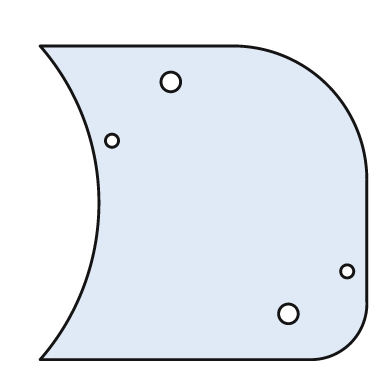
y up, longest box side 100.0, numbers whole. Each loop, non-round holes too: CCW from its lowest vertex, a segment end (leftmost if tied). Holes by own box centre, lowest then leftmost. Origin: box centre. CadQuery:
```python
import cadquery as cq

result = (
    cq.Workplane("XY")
    .moveTo(-50.0, -48.0)
    .lineTo(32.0, -48.0)
    .threePointArc((45.0, -43.0), (50.0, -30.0))
    .lineTo(50.0, 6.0)
    .threePointArc((38.0, 36.0), (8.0, 48.0))
    .lineTo(-50.0, 48.0)
    .threePointArc((-32.0, 0.0), (-50.0, -48.0))
    .close()
    .moveTo(26.0, -34.0)
    .circle(3.0)
    .moveTo(44.0, -21.0)
    .circle(2.0)
    .moveTo(-28.0, 19.0)
    .circle(2.0)
    .moveTo(-10.0, 37.0)
    .circle(3.0)
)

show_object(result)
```